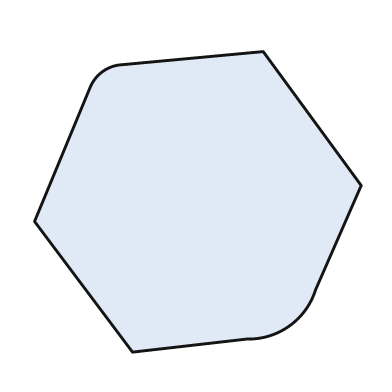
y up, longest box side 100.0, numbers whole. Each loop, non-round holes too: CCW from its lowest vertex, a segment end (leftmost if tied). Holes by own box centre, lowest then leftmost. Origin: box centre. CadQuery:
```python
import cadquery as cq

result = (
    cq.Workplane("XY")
    .moveTo(-20.0, -46.0)
    .lineTo(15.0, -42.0)
    .threePointArc((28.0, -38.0), (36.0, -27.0))
    .lineTo(50.0, 5.0)
    .lineTo(20.0, 46.0)
    .lineTo(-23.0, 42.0)
    .threePointArc((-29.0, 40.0), (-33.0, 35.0))
    .lineTo(-50.0, -6.0)
    .close()
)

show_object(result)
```